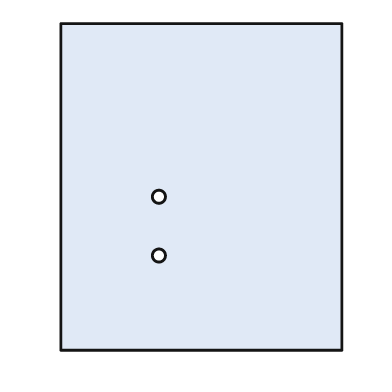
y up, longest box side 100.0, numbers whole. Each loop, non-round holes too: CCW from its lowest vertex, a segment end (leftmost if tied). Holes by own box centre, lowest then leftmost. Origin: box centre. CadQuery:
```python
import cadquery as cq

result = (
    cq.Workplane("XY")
    .moveTo(-43.0, -50.0)
    .lineTo(43.0, -50.0)
    .lineTo(43.0, 50.0)
    .lineTo(-43.0, 50.0)
    .close()
    .moveTo(-13.0, -21.0)
    .circle(2.0)
    .moveTo(-13.0, -3.0)
    .circle(2.0)
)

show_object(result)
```